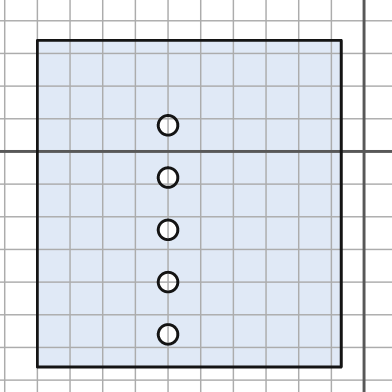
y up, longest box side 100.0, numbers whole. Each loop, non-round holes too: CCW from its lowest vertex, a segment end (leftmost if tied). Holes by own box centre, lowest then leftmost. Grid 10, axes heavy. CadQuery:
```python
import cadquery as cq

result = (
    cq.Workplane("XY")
    .moveTo(-100.0, -66.0)
    .lineTo(-7.0, -66.0)
    .lineTo(-7.0, 34.0)
    .lineTo(-100.0, 34.0)
    .close()
    .moveTo(-60.0, -56.0)
    .circle(3.0)
    .moveTo(-60.0, -40.0)
    .circle(3.0)
    .moveTo(-60.0, -24.0)
    .circle(3.0)
    .moveTo(-60.0, -8.0)
    .circle(3.0)
    .moveTo(-60.0, 8.0)
    .circle(3.0)
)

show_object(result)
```